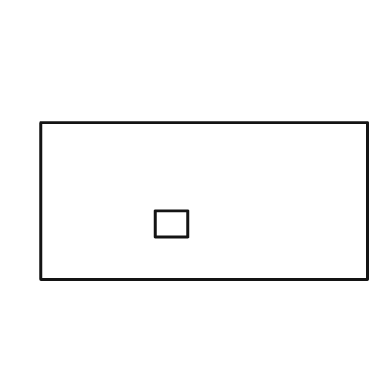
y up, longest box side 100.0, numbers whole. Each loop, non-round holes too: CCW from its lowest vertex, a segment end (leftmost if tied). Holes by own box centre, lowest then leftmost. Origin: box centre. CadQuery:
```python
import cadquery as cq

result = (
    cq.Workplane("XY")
    .moveTo(-50.0, -24.0)
    .lineTo(50.0, -24.0)
    .lineTo(50.0, 24.0)
    .lineTo(-50.0, 24.0)
    .close()
    .moveTo(-15.0, -11.0)
    .lineTo(-5.0, -11.0)
    .lineTo(-5.0, -3.0)
    .lineTo(-15.0, -3.0)
    .close()
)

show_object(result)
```